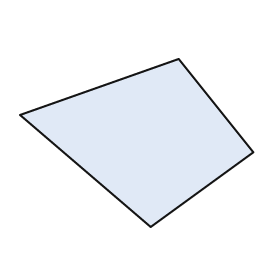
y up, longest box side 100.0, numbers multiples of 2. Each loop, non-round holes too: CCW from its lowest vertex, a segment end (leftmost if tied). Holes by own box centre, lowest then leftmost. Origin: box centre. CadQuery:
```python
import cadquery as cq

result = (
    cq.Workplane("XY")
    .moveTo(6.0, -36.0)
    .lineTo(50.0, -4.0)
    .lineTo(18.0, 36.0)
    .lineTo(-50.0, 12.0)
    .close()
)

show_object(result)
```